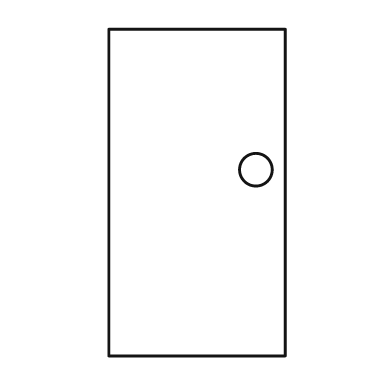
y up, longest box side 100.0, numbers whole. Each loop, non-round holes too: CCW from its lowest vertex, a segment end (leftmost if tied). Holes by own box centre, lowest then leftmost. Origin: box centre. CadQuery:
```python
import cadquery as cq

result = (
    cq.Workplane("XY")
    .moveTo(-27.0, -50.0)
    .lineTo(27.0, -50.0)
    .lineTo(27.0, 50.0)
    .lineTo(-27.0, 50.0)
    .close()
    .moveTo(18.0, 7.0)
    .circle(5.0)
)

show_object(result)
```